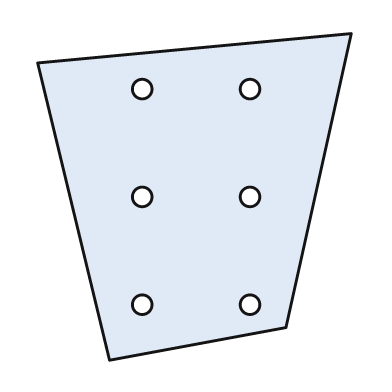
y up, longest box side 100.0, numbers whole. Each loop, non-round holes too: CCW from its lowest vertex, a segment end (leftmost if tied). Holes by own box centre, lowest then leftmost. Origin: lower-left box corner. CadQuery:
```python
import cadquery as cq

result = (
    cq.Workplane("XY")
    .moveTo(22.0, 0.0)
    .lineTo(76.0, 10.0)
    .lineTo(96.0, 100.0)
    .lineTo(0.0, 91.0)
    .close()
    .moveTo(32.0, 17.0)
    .circle(3.0)
    .moveTo(65.0, 17.0)
    .circle(3.0)
    .moveTo(32.0, 50.0)
    .circle(3.0)
    .moveTo(65.0, 50.0)
    .circle(3.0)
    .moveTo(32.0, 83.0)
    .circle(3.0)
    .moveTo(65.0, 83.0)
    .circle(3.0)
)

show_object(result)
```